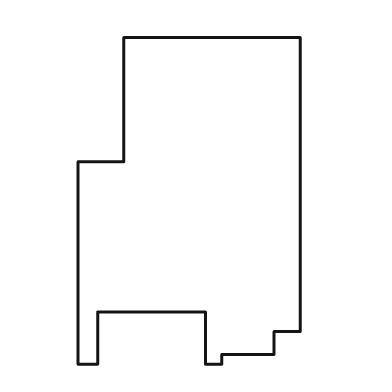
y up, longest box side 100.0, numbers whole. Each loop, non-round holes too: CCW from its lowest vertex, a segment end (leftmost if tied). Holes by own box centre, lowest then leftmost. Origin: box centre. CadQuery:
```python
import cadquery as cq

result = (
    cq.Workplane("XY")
    .moveTo(-34.0, -50.0)
    .lineTo(-28.0, -50.0)
    .lineTo(-28.0, -34.0)
    .lineTo(5.0, -34.0)
    .lineTo(5.0, -50.0)
    .lineTo(10.0, -50.0)
    .lineTo(10.0, -47.0)
    .lineTo(26.0, -47.0)
    .lineTo(26.0, -40.0)
    .lineTo(34.0, -40.0)
    .lineTo(34.0, 50.0)
    .lineTo(-20.0, 50.0)
    .lineTo(-20.0, 12.0)
    .lineTo(-34.0, 12.0)
    .close()
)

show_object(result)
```